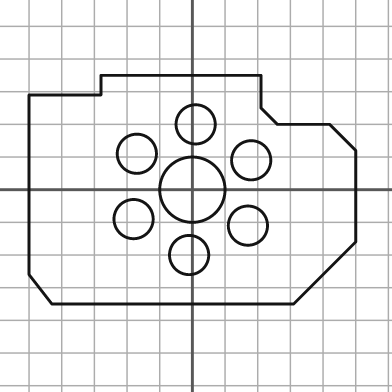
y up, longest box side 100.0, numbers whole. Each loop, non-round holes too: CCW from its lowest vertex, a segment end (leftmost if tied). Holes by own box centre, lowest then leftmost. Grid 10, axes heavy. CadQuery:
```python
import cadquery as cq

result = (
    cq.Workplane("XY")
    .moveTo(-43.0, -35.0)
    .lineTo(31.0, -35.0)
    .lineTo(50.0, -16.0)
    .lineTo(50.0, 12.0)
    .lineTo(42.0, 20.0)
    .lineTo(26.0, 20.0)
    .lineTo(21.0, 25.0)
    .lineTo(21.0, 35.0)
    .lineTo(-28.0, 35.0)
    .lineTo(-28.0, 29.0)
    .lineTo(-50.0, 29.0)
    .lineTo(-50.0, -26.0)
    .close()
    .moveTo(-1.0, -20.0)
    .circle(6.0)
    .moveTo(17.0, -11.0)
    .circle(6.0)
    .moveTo(-18.0, -9.0)
    .circle(6.0)
    .moveTo(0.0, 0.0)
    .circle(10.0)
    .moveTo(18.0, 9.0)
    .circle(6.0)
    .moveTo(-17.0, 11.0)
    .circle(6.0)
    .moveTo(1.0, 20.0)
    .circle(6.0)
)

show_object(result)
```